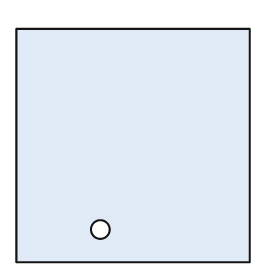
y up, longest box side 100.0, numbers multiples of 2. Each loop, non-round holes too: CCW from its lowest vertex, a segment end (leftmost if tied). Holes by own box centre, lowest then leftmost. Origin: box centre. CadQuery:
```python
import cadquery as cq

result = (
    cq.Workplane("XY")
    .moveTo(-50.0, -50.0)
    .lineTo(50.0, -50.0)
    .lineTo(50.0, 50.0)
    .lineTo(-50.0, 50.0)
    .close()
    .moveTo(-14.0, -36.0)
    .circle(4.0)
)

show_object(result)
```